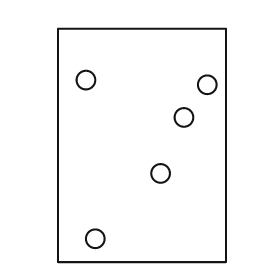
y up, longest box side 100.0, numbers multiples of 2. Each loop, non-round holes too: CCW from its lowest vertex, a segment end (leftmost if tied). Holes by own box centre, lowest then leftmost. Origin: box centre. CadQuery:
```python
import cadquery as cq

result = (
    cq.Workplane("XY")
    .moveTo(-36.0, -50.0)
    .lineTo(36.0, -50.0)
    .lineTo(36.0, 50.0)
    .lineTo(-36.0, 50.0)
    .close()
    .moveTo(-20.0, -40.0)
    .circle(4.0)
    .moveTo(8.0, -12.0)
    .circle(4.0)
    .moveTo(18.0, 12.0)
    .circle(4.0)
    .moveTo(28.0, 26.0)
    .circle(4.0)
    .moveTo(-24.0, 28.0)
    .circle(4.0)
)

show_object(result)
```